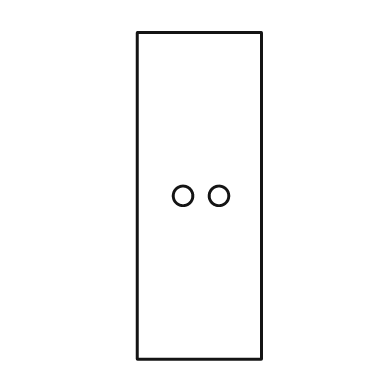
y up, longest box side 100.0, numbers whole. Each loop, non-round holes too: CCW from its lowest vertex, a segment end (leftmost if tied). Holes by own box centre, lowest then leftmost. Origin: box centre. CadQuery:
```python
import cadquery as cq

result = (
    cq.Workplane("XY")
    .moveTo(-19.0, -50.0)
    .lineTo(19.0, -50.0)
    .lineTo(19.0, 50.0)
    .lineTo(-19.0, 50.0)
    .close()
    .moveTo(-5.0, 0.0)
    .circle(3.0)
    .moveTo(6.0, 0.0)
    .circle(3.0)
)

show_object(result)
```